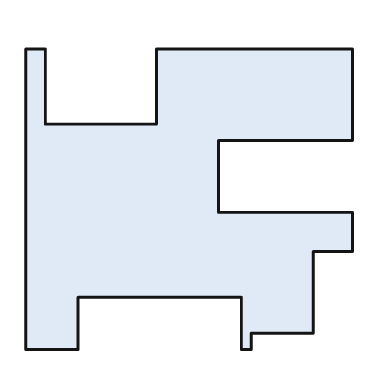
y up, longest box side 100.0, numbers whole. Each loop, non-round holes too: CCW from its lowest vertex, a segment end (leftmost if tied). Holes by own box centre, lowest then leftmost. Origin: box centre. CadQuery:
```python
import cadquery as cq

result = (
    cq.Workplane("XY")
    .moveTo(-50.0, -46.0)
    .lineTo(-34.0, -46.0)
    .lineTo(-34.0, -30.0)
    .lineTo(16.0, -30.0)
    .lineTo(16.0, -46.0)
    .lineTo(19.0, -46.0)
    .lineTo(19.0, -41.0)
    .lineTo(38.0, -41.0)
    .lineTo(38.0, -16.0)
    .lineTo(50.0, -16.0)
    .lineTo(50.0, -4.0)
    .lineTo(9.0, -4.0)
    .lineTo(9.0, 18.0)
    .lineTo(50.0, 18.0)
    .lineTo(50.0, 46.0)
    .lineTo(-10.0, 46.0)
    .lineTo(-10.0, 23.0)
    .lineTo(-44.0, 23.0)
    .lineTo(-44.0, 46.0)
    .lineTo(-50.0, 46.0)
    .close()
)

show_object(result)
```